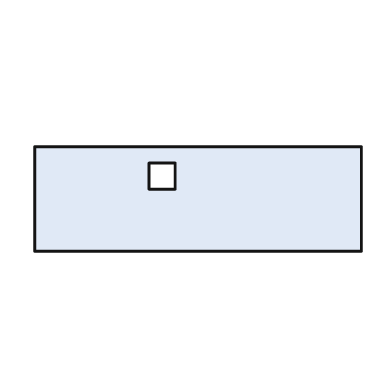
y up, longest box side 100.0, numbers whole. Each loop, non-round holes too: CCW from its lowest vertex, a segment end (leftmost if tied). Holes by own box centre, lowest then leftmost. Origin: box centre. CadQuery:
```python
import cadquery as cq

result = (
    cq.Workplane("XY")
    .moveTo(-50.0, -16.0)
    .lineTo(50.0, -16.0)
    .lineTo(50.0, 16.0)
    .lineTo(-50.0, 16.0)
    .close()
    .moveTo(-15.0, 3.0)
    .lineTo(-7.0, 3.0)
    .lineTo(-7.0, 11.0)
    .lineTo(-15.0, 11.0)
    .close()
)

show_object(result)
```